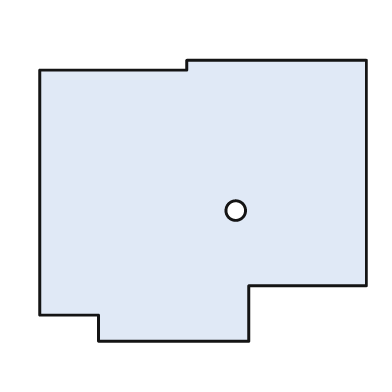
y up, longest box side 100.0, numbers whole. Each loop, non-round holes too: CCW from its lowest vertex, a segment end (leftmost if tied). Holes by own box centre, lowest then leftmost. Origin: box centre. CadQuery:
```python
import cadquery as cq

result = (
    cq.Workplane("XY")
    .moveTo(-32.0, -43.0)
    .lineTo(14.0, -43.0)
    .lineTo(14.0, -26.0)
    .lineTo(50.0, -26.0)
    .lineTo(50.0, 43.0)
    .lineTo(-5.0, 43.0)
    .lineTo(-5.0, 40.0)
    .lineTo(-50.0, 40.0)
    .lineTo(-50.0, -35.0)
    .lineTo(-32.0, -35.0)
    .close()
    .moveTo(10.0, -3.0)
    .circle(3.0)
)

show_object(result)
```